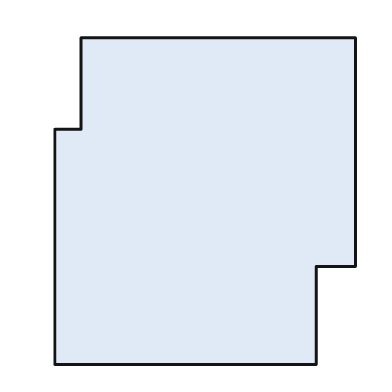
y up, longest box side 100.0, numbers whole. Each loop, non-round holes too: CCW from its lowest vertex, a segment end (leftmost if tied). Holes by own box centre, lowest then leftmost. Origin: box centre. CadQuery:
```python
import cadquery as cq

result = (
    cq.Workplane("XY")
    .moveTo(-46.0, -50.0)
    .lineTo(34.0, -50.0)
    .lineTo(34.0, -20.0)
    .lineTo(46.0, -20.0)
    .lineTo(46.0, 50.0)
    .lineTo(-38.0, 50.0)
    .lineTo(-38.0, 22.0)
    .lineTo(-46.0, 22.0)
    .close()
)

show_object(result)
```